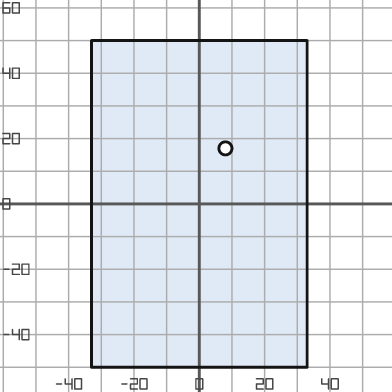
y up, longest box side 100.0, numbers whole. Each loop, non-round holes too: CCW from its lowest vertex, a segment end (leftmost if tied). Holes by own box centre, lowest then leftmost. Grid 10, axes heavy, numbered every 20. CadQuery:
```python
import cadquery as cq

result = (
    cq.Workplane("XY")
    .moveTo(-33.0, -50.0)
    .lineTo(33.0, -50.0)
    .lineTo(33.0, 50.0)
    .lineTo(-33.0, 50.0)
    .close()
    .moveTo(8.0, 17.0)
    .circle(2.0)
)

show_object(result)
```